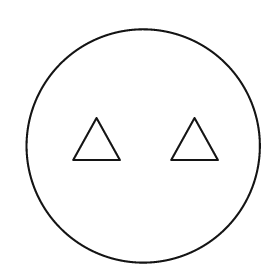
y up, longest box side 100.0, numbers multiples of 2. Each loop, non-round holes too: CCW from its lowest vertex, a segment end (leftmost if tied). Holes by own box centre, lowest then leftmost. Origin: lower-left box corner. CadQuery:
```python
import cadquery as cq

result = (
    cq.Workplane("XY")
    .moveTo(50.0, 50.0)
    .circle(50.0)
    .moveTo(20.0, 44.0)
    .lineTo(40.0, 44.0)
    .lineTo(30.0, 62.0)
    .close()
    .moveTo(62.0, 44.0)
    .lineTo(82.0, 44.0)
    .lineTo(72.0, 62.0)
    .close()
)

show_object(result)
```